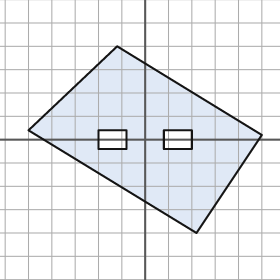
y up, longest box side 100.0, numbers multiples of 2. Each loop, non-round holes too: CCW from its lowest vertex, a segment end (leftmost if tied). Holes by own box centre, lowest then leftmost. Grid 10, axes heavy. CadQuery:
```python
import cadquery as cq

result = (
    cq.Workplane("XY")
    .moveTo(22.0, -40.0)
    .lineTo(50.0, 2.0)
    .lineTo(-12.0, 40.0)
    .lineTo(-50.0, 4.0)
    .close()
    .moveTo(-20.0, -4.0)
    .lineTo(-8.0, -4.0)
    .lineTo(-8.0, 4.0)
    .lineTo(-20.0, 4.0)
    .close()
    .moveTo(8.0, -4.0)
    .lineTo(20.0, -4.0)
    .lineTo(20.0, 4.0)
    .lineTo(8.0, 4.0)
    .close()
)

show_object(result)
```